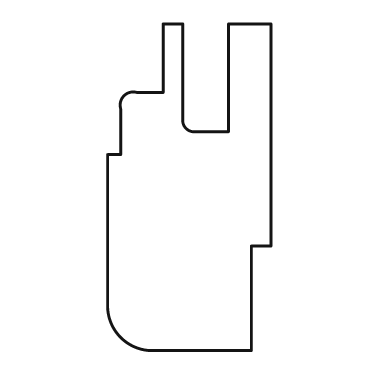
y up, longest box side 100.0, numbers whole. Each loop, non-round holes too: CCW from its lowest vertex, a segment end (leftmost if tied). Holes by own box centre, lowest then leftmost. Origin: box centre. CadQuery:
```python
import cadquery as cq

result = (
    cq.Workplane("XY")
    .moveTo(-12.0, -50.0)
    .lineTo(19.0, -50.0)
    .lineTo(19.0, -18.0)
    .lineTo(25.0, -18.0)
    .lineTo(25.0, 50.0)
    .lineTo(12.0, 50.0)
    .lineTo(12.0, 17.0)
    .lineTo(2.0, 17.0)
    .threePointArc((-1.0, 18.0), (-2.0, 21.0))
    .lineTo(-2.0, 50.0)
    .lineTo(-8.0, 50.0)
    .lineTo(-8.0, 29.0)
    .lineTo(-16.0, 29.0)
    .threePointArc((-20.0, 28.0), (-21.0, 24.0))
    .lineTo(-21.0, 10.0)
    .lineTo(-25.0, 10.0)
    .lineTo(-25.0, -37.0)
    .threePointArc((-21.0, -46.0), (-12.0, -50.0))
    .close()
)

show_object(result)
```